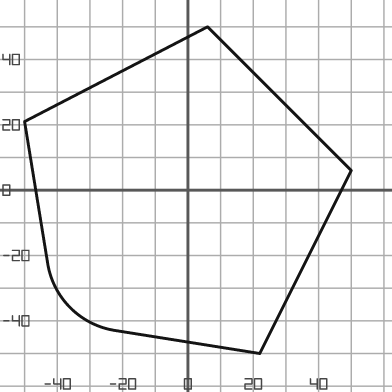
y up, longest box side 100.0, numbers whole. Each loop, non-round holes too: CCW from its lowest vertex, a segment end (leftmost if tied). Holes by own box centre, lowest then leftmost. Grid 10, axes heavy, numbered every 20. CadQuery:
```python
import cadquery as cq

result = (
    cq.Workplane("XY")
    .moveTo(22.0, -50.0)
    .lineTo(50.0, 6.0)
    .lineTo(6.0, 50.0)
    .lineTo(-50.0, 21.0)
    .lineTo(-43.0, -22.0)
    .threePointArc((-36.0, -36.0), (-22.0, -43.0))
    .close()
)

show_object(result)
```